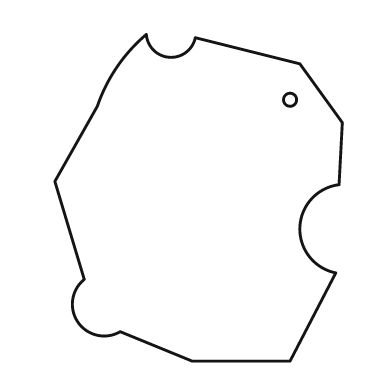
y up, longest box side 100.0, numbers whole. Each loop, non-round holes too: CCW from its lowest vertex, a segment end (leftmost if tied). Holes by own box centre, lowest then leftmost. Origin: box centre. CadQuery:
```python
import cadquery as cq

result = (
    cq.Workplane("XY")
    .moveTo(-2.0, -50.0)
    .lineTo(28.0, -50.0)
    .lineTo(42.0, -23.0)
    .threePointArc((31.0, -9.0), (43.0, 4.0))
    .lineTo(44.0, 23.0)
    .lineTo(31.0, 41.0)
    .lineTo(-1.0, 49.0)
    .threePointArc((-9.0, 43.0), (-16.0, 50.0))
    .threePointArc((-25.0, 40.0), (-31.0, 28.0))
    .lineTo(-44.0, 5.0)
    .lineTo(-35.0, -25.0)
    .threePointArc((-37.0, -38.0), (-24.0, -41.0))
    .close()
    .moveTo(28.0, 30.0)
    .circle(2.0)
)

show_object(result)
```